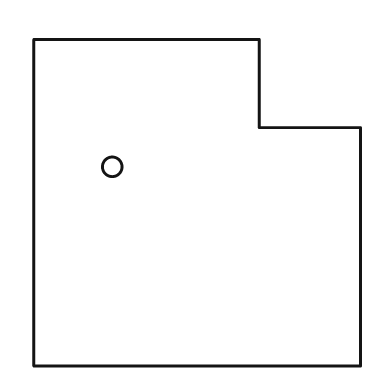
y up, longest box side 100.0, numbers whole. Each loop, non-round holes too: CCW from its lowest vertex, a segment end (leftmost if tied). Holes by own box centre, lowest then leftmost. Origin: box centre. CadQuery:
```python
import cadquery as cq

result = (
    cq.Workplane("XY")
    .moveTo(-50.0, -50.0)
    .lineTo(50.0, -50.0)
    .lineTo(50.0, 23.0)
    .lineTo(19.0, 23.0)
    .lineTo(19.0, 50.0)
    .lineTo(-50.0, 50.0)
    .close()
    .moveTo(-26.0, 11.0)
    .circle(3.0)
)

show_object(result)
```